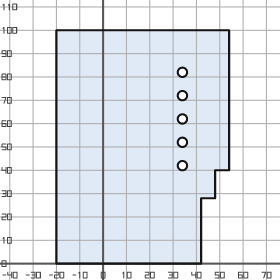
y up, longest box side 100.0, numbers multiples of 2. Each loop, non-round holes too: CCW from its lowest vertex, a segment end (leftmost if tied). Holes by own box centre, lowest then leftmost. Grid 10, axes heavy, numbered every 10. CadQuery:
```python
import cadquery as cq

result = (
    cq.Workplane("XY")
    .moveTo(-20.0, 0.0)
    .lineTo(42.0, 0.0)
    .lineTo(42.0, 28.0)
    .lineTo(48.0, 28.0)
    .lineTo(48.0, 40.0)
    .lineTo(54.0, 40.0)
    .lineTo(54.0, 100.0)
    .lineTo(-20.0, 100.0)
    .close()
    .moveTo(34.0, 42.0)
    .circle(2.0)
    .moveTo(34.0, 52.0)
    .circle(2.0)
    .moveTo(34.0, 62.0)
    .circle(2.0)
    .moveTo(34.0, 72.0)
    .circle(2.0)
    .moveTo(34.0, 82.0)
    .circle(2.0)
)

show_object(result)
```